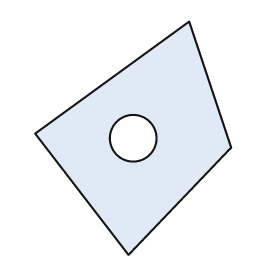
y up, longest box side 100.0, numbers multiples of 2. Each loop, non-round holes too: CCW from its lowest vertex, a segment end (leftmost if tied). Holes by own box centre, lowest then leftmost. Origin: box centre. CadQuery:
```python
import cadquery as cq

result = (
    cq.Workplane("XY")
    .moveTo(-2.0, -50.0)
    .lineTo(42.0, -4.0)
    .lineTo(24.0, 50.0)
    .lineTo(-42.0, 2.0)
    .close()
    .moveTo(0.0, 0.0)
    .circle(10.0)
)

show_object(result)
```